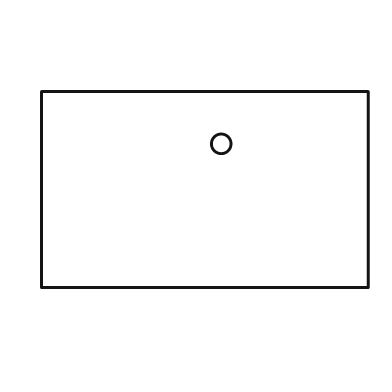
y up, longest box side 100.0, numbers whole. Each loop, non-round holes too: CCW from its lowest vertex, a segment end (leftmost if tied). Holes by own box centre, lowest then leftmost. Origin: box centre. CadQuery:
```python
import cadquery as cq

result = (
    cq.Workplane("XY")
    .moveTo(-50.0, -30.0)
    .lineTo(50.0, -30.0)
    .lineTo(50.0, 30.0)
    .lineTo(-50.0, 30.0)
    .close()
    .moveTo(5.0, 14.0)
    .circle(3.0)
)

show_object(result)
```